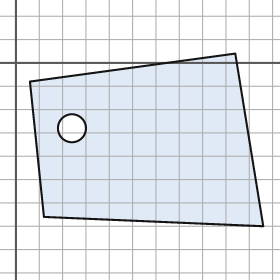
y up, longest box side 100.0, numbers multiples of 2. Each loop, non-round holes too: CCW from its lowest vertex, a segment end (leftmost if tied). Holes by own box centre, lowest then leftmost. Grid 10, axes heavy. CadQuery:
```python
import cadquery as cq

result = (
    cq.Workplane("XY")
    .moveTo(106.0, -70.0)
    .lineTo(94.0, 4.0)
    .lineTo(6.0, -8.0)
    .lineTo(12.0, -66.0)
    .close()
    .moveTo(24.0, -28.0)
    .circle(6.0)
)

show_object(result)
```